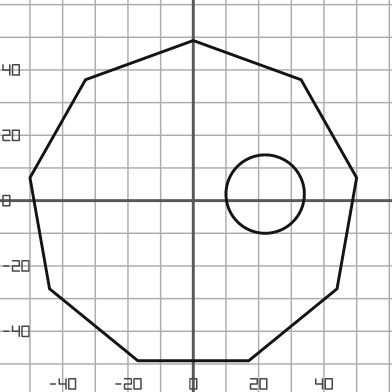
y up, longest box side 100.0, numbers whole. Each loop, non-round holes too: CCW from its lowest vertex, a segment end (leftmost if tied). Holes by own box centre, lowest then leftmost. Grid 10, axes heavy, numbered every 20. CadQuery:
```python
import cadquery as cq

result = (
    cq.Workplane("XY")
    .moveTo(-17.0, -49.0)
    .lineTo(17.0, -49.0)
    .lineTo(44.0, -27.0)
    .lineTo(50.0, 7.0)
    .lineTo(33.0, 37.0)
    .lineTo(0.0, 49.0)
    .lineTo(-33.0, 37.0)
    .lineTo(-50.0, 7.0)
    .lineTo(-44.0, -27.0)
    .close()
    .moveTo(22.0, 2.0)
    .circle(12.0)
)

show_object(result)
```